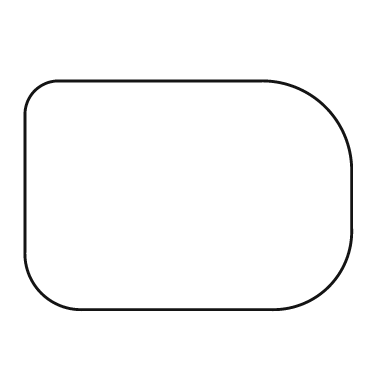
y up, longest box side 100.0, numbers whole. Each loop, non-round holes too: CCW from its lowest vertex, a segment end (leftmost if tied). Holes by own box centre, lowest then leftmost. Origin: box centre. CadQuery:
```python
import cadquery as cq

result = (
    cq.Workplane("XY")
    .moveTo(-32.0, -35.0)
    .lineTo(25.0, -35.0)
    .threePointArc((43.0, -28.0), (50.0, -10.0))
    .lineTo(50.0, 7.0)
    .threePointArc((42.0, 27.0), (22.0, 35.0))
    .lineTo(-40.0, 35.0)
    .threePointArc((-47.0, 32.0), (-50.0, 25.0))
    .lineTo(-50.0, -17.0)
    .threePointArc((-45.0, -30.0), (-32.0, -35.0))
    .close()
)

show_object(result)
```